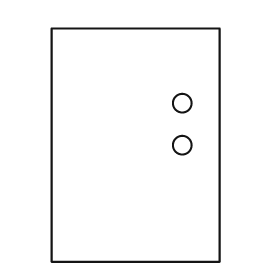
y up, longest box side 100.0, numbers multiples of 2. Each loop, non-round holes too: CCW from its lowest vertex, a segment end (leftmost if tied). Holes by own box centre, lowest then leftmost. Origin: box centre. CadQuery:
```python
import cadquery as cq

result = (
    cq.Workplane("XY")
    .moveTo(-36.0, -50.0)
    .lineTo(36.0, -50.0)
    .lineTo(36.0, 50.0)
    .lineTo(-36.0, 50.0)
    .close()
    .moveTo(20.0, 0.0)
    .circle(4.0)
    .moveTo(20.0, 18.0)
    .circle(4.0)
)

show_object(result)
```